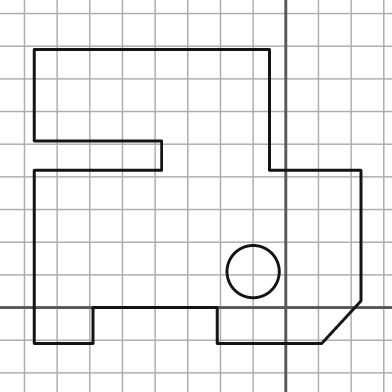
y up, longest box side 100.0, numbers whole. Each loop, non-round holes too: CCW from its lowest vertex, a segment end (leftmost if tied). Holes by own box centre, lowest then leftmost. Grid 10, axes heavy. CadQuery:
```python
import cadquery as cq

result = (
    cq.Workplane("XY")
    .moveTo(-77.0, -11.0)
    .lineTo(-59.0, -11.0)
    .lineTo(-59.0, 0.0)
    .lineTo(-21.0, 0.0)
    .lineTo(-21.0, -11.0)
    .lineTo(11.0, -11.0)
    .lineTo(23.0, 2.0)
    .lineTo(23.0, 42.0)
    .lineTo(-5.0, 42.0)
    .lineTo(-5.0, 79.0)
    .lineTo(-77.0, 79.0)
    .lineTo(-77.0, 51.0)
    .lineTo(-38.0, 51.0)
    .lineTo(-38.0, 42.0)
    .lineTo(-77.0, 42.0)
    .close()
    .moveTo(-10.0, 11.0)
    .circle(8.0)
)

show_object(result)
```